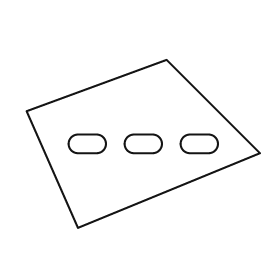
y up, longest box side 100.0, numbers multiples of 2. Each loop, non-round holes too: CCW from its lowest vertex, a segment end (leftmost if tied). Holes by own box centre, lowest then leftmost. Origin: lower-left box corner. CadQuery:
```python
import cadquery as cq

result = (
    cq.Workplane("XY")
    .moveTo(22.0, 0.0)
    .lineTo(100.0, 32.0)
    .lineTo(60.0, 72.0)
    .lineTo(0.0, 50.0)
    .close()
    .moveTo(22.0, 32.0)
    .lineTo(30.0, 32.0)
    .threePointArc((34.0, 36.0), (30.0, 40.0))
    .lineTo(22.0, 40.0)
    .threePointArc((18.0, 36.0), (22.0, 32.0))
    .close()
    .moveTo(46.0, 32.0)
    .lineTo(54.0, 32.0)
    .threePointArc((58.0, 36.0), (54.0, 40.0))
    .lineTo(46.0, 40.0)
    .threePointArc((42.0, 36.0), (46.0, 32.0))
    .close()
    .moveTo(70.0, 32.0)
    .lineTo(78.0, 32.0)
    .threePointArc((82.0, 36.0), (78.0, 40.0))
    .lineTo(70.0, 40.0)
    .threePointArc((66.0, 36.0), (70.0, 32.0))
    .close()
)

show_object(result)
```